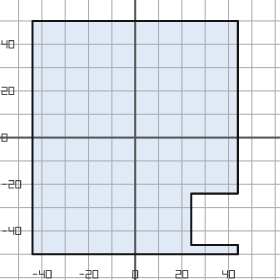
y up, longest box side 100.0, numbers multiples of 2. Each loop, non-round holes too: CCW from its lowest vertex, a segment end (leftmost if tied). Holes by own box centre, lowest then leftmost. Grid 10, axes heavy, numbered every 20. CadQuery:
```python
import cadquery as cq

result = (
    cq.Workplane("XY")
    .moveTo(-44.0, -50.0)
    .lineTo(44.0, -50.0)
    .lineTo(44.0, -46.0)
    .lineTo(24.0, -46.0)
    .lineTo(24.0, -24.0)
    .lineTo(44.0, -24.0)
    .lineTo(44.0, 50.0)
    .lineTo(-44.0, 50.0)
    .close()
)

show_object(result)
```